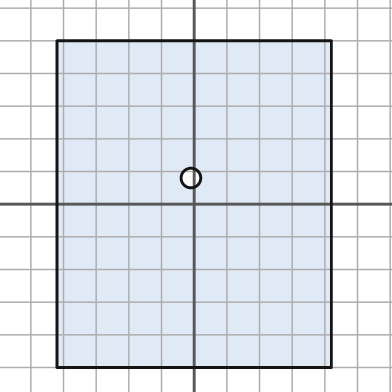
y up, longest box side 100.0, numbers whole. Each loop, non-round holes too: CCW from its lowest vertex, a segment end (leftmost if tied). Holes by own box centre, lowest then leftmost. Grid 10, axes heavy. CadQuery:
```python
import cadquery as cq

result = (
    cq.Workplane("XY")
    .moveTo(-42.0, -50.0)
    .lineTo(42.0, -50.0)
    .lineTo(42.0, 50.0)
    .lineTo(-42.0, 50.0)
    .close()
    .moveTo(-1.0, 8.0)
    .circle(3.0)
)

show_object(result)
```